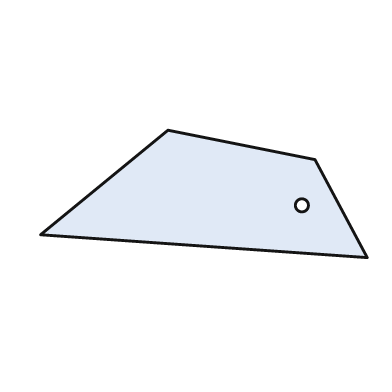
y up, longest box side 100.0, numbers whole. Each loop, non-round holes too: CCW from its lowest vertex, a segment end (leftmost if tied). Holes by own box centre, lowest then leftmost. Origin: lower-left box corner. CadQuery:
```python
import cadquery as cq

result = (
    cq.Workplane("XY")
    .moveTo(100.0, 0.0)
    .lineTo(84.0, 30.0)
    .lineTo(39.0, 39.0)
    .lineTo(0.0, 7.0)
    .close()
    .moveTo(80.0, 16.0)
    .circle(2.0)
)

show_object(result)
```